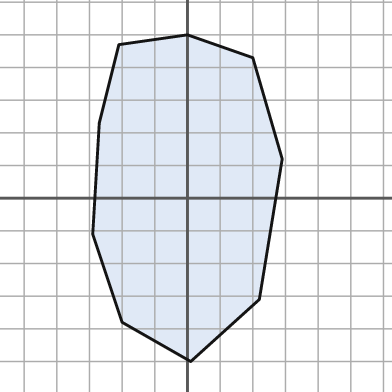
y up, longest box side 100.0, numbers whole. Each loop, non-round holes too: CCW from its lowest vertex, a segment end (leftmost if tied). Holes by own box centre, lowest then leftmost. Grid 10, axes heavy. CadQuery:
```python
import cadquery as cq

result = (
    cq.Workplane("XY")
    .moveTo(1.0, -50.0)
    .lineTo(22.0, -31.0)
    .lineTo(29.0, 12.0)
    .lineTo(20.0, 43.0)
    .lineTo(0.0, 50.0)
    .lineTo(-21.0, 47.0)
    .lineTo(-27.0, 23.0)
    .lineTo(-29.0, -11.0)
    .lineTo(-20.0, -38.0)
    .close()
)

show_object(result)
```